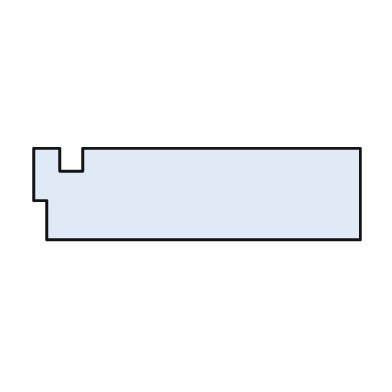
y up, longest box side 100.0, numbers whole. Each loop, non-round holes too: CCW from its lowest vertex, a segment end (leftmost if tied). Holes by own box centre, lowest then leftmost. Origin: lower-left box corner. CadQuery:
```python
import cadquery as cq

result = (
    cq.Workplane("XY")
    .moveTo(4.0, 0.0)
    .lineTo(100.0, 0.0)
    .lineTo(100.0, 28.0)
    .lineTo(15.0, 28.0)
    .lineTo(15.0, 21.0)
    .lineTo(8.0, 21.0)
    .lineTo(8.0, 28.0)
    .lineTo(0.0, 28.0)
    .lineTo(0.0, 12.0)
    .lineTo(4.0, 12.0)
    .close()
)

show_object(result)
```